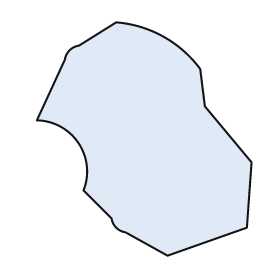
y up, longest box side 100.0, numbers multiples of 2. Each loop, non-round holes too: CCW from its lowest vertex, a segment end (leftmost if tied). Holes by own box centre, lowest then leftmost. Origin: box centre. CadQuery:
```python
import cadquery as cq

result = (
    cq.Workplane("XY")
    .moveTo(10.0, -50.0)
    .lineTo(44.0, -38.0)
    .lineTo(46.0, -10.0)
    .lineTo(26.0, 14.0)
    .lineTo(24.0, 30.0)
    .threePointArc((8.0, 44.0), (-12.0, 50.0))
    .lineTo(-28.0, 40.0)
    .threePointArc((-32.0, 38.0), (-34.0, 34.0))
    .lineTo(-46.0, 8.0)
    .threePointArc((-28.0, -2.0), (-26.0, -22.0))
    .lineTo(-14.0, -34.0)
    .threePointArc((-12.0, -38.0), (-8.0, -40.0))
    .close()
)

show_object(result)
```